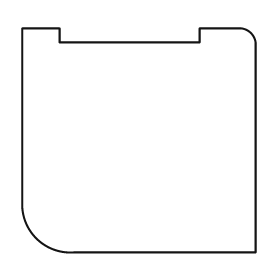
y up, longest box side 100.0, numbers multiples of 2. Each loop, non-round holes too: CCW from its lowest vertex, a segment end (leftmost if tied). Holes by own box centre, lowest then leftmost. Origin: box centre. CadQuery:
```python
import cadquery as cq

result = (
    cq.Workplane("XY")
    .moveTo(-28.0, -48.0)
    .lineTo(50.0, -48.0)
    .lineTo(50.0, 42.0)
    .threePointArc((48.0, 46.0), (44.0, 48.0))
    .lineTo(26.0, 48.0)
    .lineTo(26.0, 42.0)
    .lineTo(-34.0, 42.0)
    .lineTo(-34.0, 48.0)
    .lineTo(-50.0, 48.0)
    .lineTo(-50.0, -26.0)
    .threePointArc((-44.0, -42.0), (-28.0, -48.0))
    .close()
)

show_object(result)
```